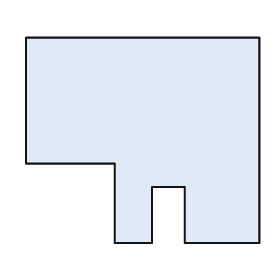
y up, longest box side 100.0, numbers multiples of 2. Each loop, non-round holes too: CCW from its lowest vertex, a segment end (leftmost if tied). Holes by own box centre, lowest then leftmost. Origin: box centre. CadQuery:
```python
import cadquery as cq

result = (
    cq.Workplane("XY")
    .moveTo(-12.0, -44.0)
    .lineTo(4.0, -44.0)
    .lineTo(4.0, -20.0)
    .lineTo(18.0, -20.0)
    .lineTo(18.0, -44.0)
    .lineTo(50.0, -44.0)
    .lineTo(50.0, 44.0)
    .lineTo(-50.0, 44.0)
    .lineTo(-50.0, -10.0)
    .lineTo(-12.0, -10.0)
    .close()
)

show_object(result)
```